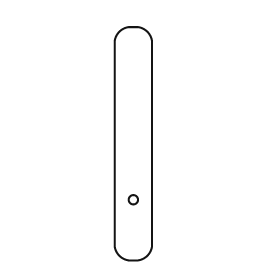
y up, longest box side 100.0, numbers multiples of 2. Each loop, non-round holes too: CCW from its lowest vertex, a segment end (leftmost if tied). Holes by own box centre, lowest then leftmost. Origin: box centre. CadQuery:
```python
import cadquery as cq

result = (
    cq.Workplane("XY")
    .moveTo(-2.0, -50.0)
    .lineTo(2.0, -50.0)
    .threePointArc((6.0, -48.0), (8.0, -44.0))
    .lineTo(8.0, 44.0)
    .threePointArc((6.0, 48.0), (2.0, 50.0))
    .lineTo(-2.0, 50.0)
    .threePointArc((-6.0, 48.0), (-8.0, 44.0))
    .lineTo(-8.0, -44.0)
    .threePointArc((-6.0, -48.0), (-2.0, -50.0))
    .close()
    .moveTo(0.0, -24.0)
    .circle(2.0)
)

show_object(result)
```